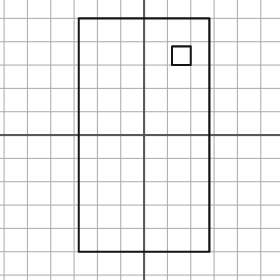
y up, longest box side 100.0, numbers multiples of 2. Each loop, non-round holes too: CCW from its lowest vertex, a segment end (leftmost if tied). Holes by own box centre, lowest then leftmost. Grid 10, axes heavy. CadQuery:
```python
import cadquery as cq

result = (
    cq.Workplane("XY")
    .moveTo(-28.0, -50.0)
    .lineTo(28.0, -50.0)
    .lineTo(28.0, 50.0)
    .lineTo(-28.0, 50.0)
    .close()
    .moveTo(12.0, 30.0)
    .lineTo(20.0, 30.0)
    .lineTo(20.0, 38.0)
    .lineTo(12.0, 38.0)
    .close()
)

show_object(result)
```